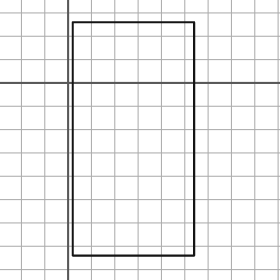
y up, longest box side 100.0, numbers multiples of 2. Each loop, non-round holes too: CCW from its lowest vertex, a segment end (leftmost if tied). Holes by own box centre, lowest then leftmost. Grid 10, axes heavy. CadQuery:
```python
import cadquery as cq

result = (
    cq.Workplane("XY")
    .moveTo(2.0, -74.0)
    .lineTo(54.0, -74.0)
    .lineTo(54.0, 26.0)
    .lineTo(2.0, 26.0)
    .close()
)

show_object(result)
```